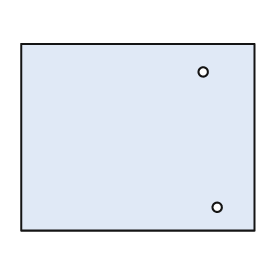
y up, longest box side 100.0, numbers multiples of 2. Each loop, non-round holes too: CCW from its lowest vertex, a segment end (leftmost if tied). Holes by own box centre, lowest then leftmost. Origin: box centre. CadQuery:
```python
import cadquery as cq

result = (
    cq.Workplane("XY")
    .moveTo(-50.0, -40.0)
    .lineTo(50.0, -40.0)
    .lineTo(50.0, 40.0)
    .lineTo(-50.0, 40.0)
    .close()
    .moveTo(34.0, -30.0)
    .circle(2.0)
    .moveTo(28.0, 28.0)
    .circle(2.0)
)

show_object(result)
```